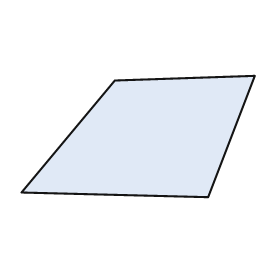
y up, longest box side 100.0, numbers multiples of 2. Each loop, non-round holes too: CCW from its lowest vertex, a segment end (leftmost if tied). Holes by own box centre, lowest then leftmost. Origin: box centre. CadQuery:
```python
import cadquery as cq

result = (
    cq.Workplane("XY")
    .moveTo(30.0, -26.0)
    .lineTo(50.0, 26.0)
    .lineTo(-10.0, 24.0)
    .lineTo(-50.0, -24.0)
    .close()
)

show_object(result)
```